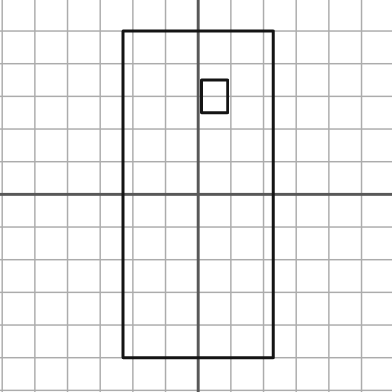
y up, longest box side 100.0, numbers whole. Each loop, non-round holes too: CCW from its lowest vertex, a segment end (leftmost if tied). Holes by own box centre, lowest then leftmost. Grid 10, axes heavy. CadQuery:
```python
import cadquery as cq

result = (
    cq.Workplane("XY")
    .moveTo(-23.0, -50.0)
    .lineTo(23.0, -50.0)
    .lineTo(23.0, 50.0)
    .lineTo(-23.0, 50.0)
    .close()
    .moveTo(1.0, 25.0)
    .lineTo(9.0, 25.0)
    .lineTo(9.0, 35.0)
    .lineTo(1.0, 35.0)
    .close()
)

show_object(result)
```